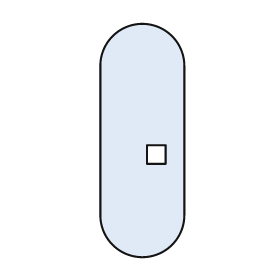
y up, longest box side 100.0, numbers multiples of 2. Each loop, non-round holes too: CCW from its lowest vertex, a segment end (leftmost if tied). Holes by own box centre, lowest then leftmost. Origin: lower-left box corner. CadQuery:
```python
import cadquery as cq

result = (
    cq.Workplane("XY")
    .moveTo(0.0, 18.0)
    .threePointArc((18.0, 0.0), (36.0, 18.0))
    .lineTo(36.0, 82.0)
    .threePointArc((18.0, 100.0), (0.0, 82.0))
    .close()
    .moveTo(20.0, 40.0)
    .lineTo(28.0, 40.0)
    .lineTo(28.0, 48.0)
    .lineTo(20.0, 48.0)
    .close()
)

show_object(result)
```